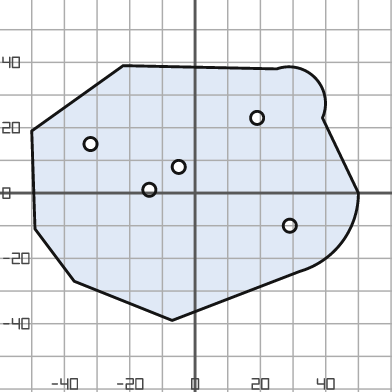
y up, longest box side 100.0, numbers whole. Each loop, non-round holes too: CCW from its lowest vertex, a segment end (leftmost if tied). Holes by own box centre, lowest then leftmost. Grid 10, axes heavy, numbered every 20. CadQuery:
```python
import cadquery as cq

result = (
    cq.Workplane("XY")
    .moveTo(-7.0, -39.0)
    .lineTo(32.0, -24.0)
    .threePointArc((45.0, -15.0), (50.0, 0.0))
    .lineTo(39.0, 23.0)
    .threePointArc((37.0, 35.0), (25.0, 38.0))
    .lineTo(-22.0, 39.0)
    .lineTo(-50.0, 19.0)
    .lineTo(-49.0, -11.0)
    .lineTo(-37.0, -27.0)
    .close()
    .moveTo(29.0, -10.0)
    .circle(2.0)
    .moveTo(-14.0, 1.0)
    .circle(2.0)
    .moveTo(-5.0, 8.0)
    .circle(2.0)
    .moveTo(-32.0, 15.0)
    .circle(2.0)
    .moveTo(19.0, 23.0)
    .circle(2.0)
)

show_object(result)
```